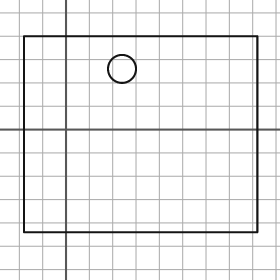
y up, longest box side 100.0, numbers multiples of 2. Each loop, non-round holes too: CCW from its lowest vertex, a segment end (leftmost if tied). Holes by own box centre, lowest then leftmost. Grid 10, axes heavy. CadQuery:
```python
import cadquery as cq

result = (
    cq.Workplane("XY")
    .moveTo(-18.0, -44.0)
    .lineTo(82.0, -44.0)
    .lineTo(82.0, 40.0)
    .lineTo(-18.0, 40.0)
    .close()
    .moveTo(24.0, 26.0)
    .circle(6.0)
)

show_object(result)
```